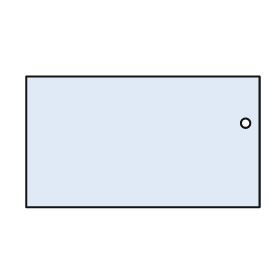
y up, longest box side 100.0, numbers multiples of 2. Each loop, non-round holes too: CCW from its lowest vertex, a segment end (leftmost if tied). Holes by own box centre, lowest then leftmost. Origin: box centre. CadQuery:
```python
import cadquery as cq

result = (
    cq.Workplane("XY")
    .moveTo(-50.0, -28.0)
    .lineTo(50.0, -28.0)
    .lineTo(50.0, 28.0)
    .lineTo(-50.0, 28.0)
    .close()
    .moveTo(44.0, 8.0)
    .circle(2.0)
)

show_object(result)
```